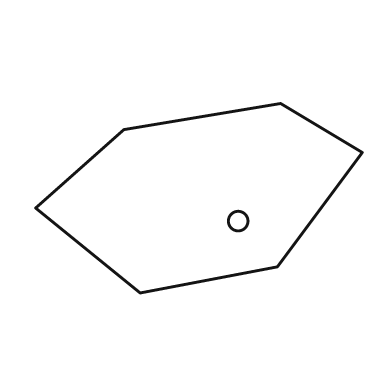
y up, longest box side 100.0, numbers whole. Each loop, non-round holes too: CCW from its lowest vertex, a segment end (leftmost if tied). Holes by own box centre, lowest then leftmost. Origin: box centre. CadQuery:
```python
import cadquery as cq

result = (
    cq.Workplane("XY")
    .moveTo(-18.0, -29.0)
    .lineTo(24.0, -21.0)
    .lineTo(50.0, 14.0)
    .lineTo(25.0, 29.0)
    .lineTo(-23.0, 21.0)
    .lineTo(-50.0, -3.0)
    .close()
    .moveTo(12.0, -7.0)
    .circle(3.0)
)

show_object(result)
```